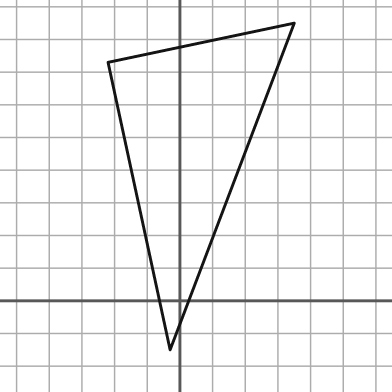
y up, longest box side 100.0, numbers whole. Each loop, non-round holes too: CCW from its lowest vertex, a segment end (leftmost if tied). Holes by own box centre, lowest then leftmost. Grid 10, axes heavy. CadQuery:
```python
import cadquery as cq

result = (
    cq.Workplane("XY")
    .moveTo(-3.0, -15.0)
    .lineTo(35.0, 85.0)
    .lineTo(-22.0, 73.0)
    .close()
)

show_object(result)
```